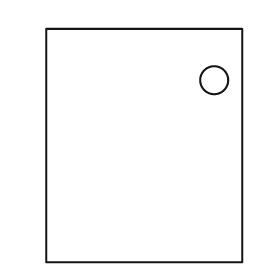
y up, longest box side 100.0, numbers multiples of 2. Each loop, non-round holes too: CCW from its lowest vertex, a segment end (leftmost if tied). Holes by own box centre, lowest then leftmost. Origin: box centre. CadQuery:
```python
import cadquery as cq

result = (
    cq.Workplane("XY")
    .moveTo(-42.0, -50.0)
    .lineTo(42.0, -50.0)
    .lineTo(42.0, 50.0)
    .lineTo(-42.0, 50.0)
    .close()
    .moveTo(30.0, 28.0)
    .circle(6.0)
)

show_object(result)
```